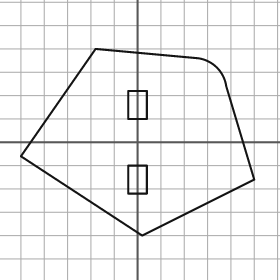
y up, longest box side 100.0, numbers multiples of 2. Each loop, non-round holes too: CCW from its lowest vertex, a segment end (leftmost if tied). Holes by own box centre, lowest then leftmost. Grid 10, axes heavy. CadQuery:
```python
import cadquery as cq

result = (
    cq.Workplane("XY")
    .moveTo(2.0, -40.0)
    .lineTo(50.0, -16.0)
    .lineTo(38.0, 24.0)
    .threePointArc((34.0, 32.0), (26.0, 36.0))
    .lineTo(-18.0, 40.0)
    .lineTo(-50.0, -6.0)
    .close()
    .moveTo(-4.0, -22.0)
    .lineTo(4.0, -22.0)
    .lineTo(4.0, -10.0)
    .lineTo(-4.0, -10.0)
    .close()
    .moveTo(-4.0, 10.0)
    .lineTo(4.0, 10.0)
    .lineTo(4.0, 22.0)
    .lineTo(-4.0, 22.0)
    .close()
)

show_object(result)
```